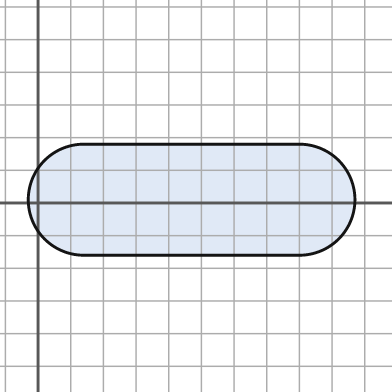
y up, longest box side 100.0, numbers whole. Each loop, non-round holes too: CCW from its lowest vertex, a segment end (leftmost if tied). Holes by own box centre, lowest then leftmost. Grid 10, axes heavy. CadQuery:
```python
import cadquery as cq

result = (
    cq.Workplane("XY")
    .moveTo(14.0, -16.0)
    .lineTo(80.0, -16.0)
    .threePointArc((97.0, 1.0), (80.0, 18.0))
    .lineTo(14.0, 18.0)
    .threePointArc((-3.0, 1.0), (14.0, -16.0))
    .close()
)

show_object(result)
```